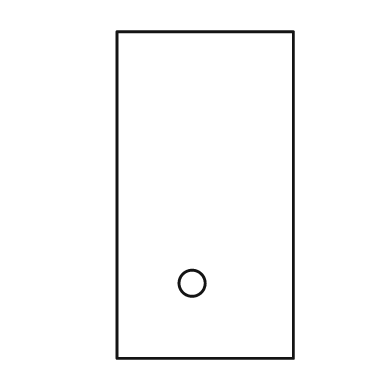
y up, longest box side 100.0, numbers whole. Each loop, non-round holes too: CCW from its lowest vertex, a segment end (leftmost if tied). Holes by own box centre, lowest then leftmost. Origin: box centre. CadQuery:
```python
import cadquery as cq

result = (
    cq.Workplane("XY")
    .moveTo(-27.0, -50.0)
    .lineTo(27.0, -50.0)
    .lineTo(27.0, 50.0)
    .lineTo(-27.0, 50.0)
    .close()
    .moveTo(-4.0, -27.0)
    .circle(4.0)
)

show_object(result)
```